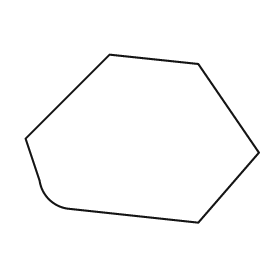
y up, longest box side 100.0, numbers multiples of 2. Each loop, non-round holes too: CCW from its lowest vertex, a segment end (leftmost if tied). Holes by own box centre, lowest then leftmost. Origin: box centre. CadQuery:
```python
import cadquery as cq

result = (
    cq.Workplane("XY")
    .moveTo(24.0, -36.0)
    .lineTo(50.0, -6.0)
    .lineTo(24.0, 32.0)
    .lineTo(-14.0, 36.0)
    .lineTo(-50.0, 0.0)
    .lineTo(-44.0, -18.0)
    .threePointArc((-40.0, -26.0), (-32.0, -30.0))
    .close()
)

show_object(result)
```